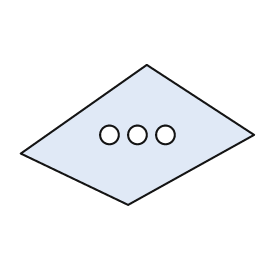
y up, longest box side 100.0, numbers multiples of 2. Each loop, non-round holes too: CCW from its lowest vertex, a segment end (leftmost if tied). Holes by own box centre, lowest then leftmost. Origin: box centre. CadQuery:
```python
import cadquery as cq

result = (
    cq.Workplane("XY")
    .moveTo(-4.0, -30.0)
    .lineTo(50.0, 0.0)
    .lineTo(4.0, 30.0)
    .lineTo(-50.0, -8.0)
    .close()
    .moveTo(-12.0, 0.0)
    .circle(4.0)
    .moveTo(0.0, 0.0)
    .circle(4.0)
    .moveTo(12.0, 0.0)
    .circle(4.0)
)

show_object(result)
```